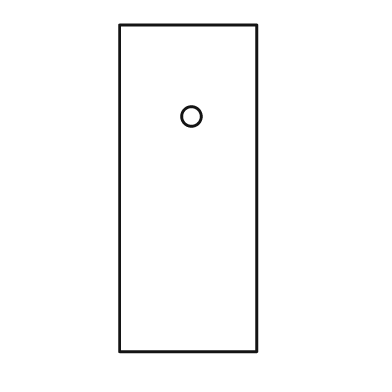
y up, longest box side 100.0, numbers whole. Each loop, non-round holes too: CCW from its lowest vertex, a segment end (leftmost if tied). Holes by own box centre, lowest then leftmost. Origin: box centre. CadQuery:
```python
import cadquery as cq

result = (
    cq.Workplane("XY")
    .moveTo(-21.0, -50.0)
    .lineTo(21.0, -50.0)
    .lineTo(21.0, 50.0)
    .lineTo(-21.0, 50.0)
    .close()
    .moveTo(1.0, 22.0)
    .circle(3.0)
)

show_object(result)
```